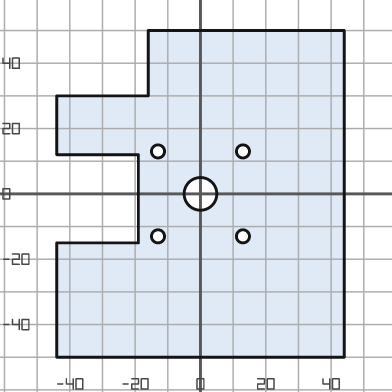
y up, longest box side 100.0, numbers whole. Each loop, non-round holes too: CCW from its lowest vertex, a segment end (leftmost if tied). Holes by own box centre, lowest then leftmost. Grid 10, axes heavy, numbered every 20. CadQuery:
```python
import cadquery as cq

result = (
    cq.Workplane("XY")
    .moveTo(-44.0, -50.0)
    .lineTo(44.0, -50.0)
    .lineTo(44.0, 50.0)
    .lineTo(-16.0, 50.0)
    .lineTo(-16.0, 30.0)
    .lineTo(-44.0, 30.0)
    .lineTo(-44.0, 12.0)
    .lineTo(-19.0, 12.0)
    .lineTo(-19.0, -15.0)
    .lineTo(-44.0, -15.0)
    .close()
    .moveTo(-13.0, -13.0)
    .circle(2.0)
    .moveTo(13.0, -13.0)
    .circle(2.0)
    .moveTo(0.0, 0.0)
    .circle(5.0)
    .moveTo(-13.0, 13.0)
    .circle(2.0)
    .moveTo(13.0, 13.0)
    .circle(2.0)
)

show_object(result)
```